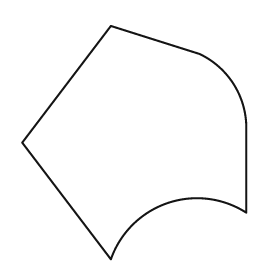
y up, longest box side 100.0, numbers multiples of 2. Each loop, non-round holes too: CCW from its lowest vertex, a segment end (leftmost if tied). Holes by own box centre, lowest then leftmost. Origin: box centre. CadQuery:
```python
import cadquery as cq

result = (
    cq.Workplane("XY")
    .moveTo(-10.0, -50.0)
    .threePointArc((14.0, -26.0), (48.0, -30.0))
    .lineTo(48.0, 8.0)
    .threePointArc((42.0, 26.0), (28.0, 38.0))
    .lineTo(-10.0, 50.0)
    .lineTo(-48.0, 0.0)
    .close()
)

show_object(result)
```